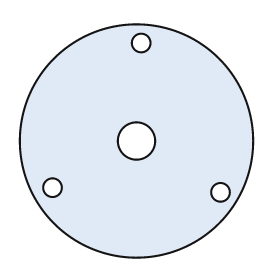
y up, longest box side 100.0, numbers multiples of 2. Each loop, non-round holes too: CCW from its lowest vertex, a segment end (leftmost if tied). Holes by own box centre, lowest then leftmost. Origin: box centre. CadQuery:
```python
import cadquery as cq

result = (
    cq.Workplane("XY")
    .moveTo(0.0, 0.0)
    .circle(50.0)
    .moveTo(36.0, -22.0)
    .circle(4.0)
    .moveTo(-36.0, -20.0)
    .circle(4.0)
    .moveTo(0.0, 0.0)
    .circle(8.0)
    .moveTo(2.0, 42.0)
    .circle(4.0)
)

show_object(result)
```